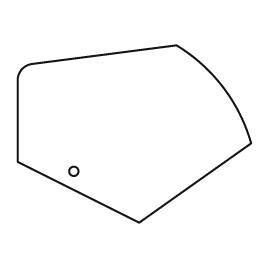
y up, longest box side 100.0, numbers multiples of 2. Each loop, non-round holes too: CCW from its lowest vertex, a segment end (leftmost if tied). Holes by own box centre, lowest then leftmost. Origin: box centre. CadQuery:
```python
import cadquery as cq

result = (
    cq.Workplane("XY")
    .moveTo(2.0, -38.0)
    .lineTo(50.0, -4.0)
    .threePointArc((38.0, 20.0), (18.0, 38.0))
    .lineTo(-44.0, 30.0)
    .threePointArc((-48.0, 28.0), (-50.0, 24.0))
    .lineTo(-50.0, -12.0)
    .close()
    .moveTo(-26.0, -16.0)
    .circle(2.0)
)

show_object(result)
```